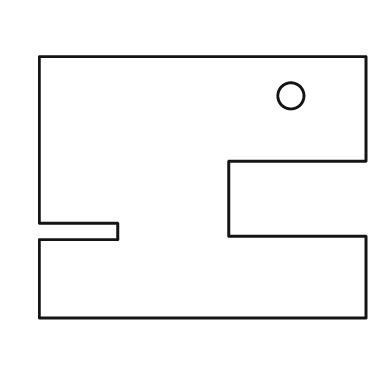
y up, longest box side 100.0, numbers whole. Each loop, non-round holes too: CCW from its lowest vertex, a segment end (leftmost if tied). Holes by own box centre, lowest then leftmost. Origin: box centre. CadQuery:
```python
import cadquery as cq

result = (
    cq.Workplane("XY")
    .moveTo(-50.0, -40.0)
    .lineTo(50.0, -40.0)
    .lineTo(50.0, -15.0)
    .lineTo(8.0, -15.0)
    .lineTo(8.0, 8.0)
    .lineTo(50.0, 8.0)
    .lineTo(50.0, 40.0)
    .lineTo(-50.0, 40.0)
    .lineTo(-50.0, -11.0)
    .lineTo(-26.0, -11.0)
    .lineTo(-26.0, -16.0)
    .lineTo(-50.0, -16.0)
    .close()
    .moveTo(27.0, 28.0)
    .circle(4.0)
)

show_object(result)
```